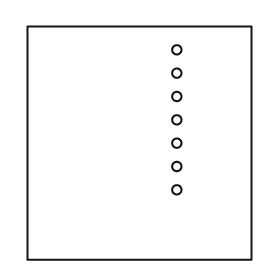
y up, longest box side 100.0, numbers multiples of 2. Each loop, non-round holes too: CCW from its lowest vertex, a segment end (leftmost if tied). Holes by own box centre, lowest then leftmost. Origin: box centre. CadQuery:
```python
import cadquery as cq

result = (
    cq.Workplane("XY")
    .moveTo(-48.0, -50.0)
    .lineTo(48.0, -50.0)
    .lineTo(48.0, 50.0)
    .lineTo(-48.0, 50.0)
    .close()
    .moveTo(16.0, -20.0)
    .circle(2.0)
    .moveTo(16.0, -10.0)
    .circle(2.0)
    .moveTo(16.0, 0.0)
    .circle(2.0)
    .moveTo(16.0, 10.0)
    .circle(2.0)
    .moveTo(16.0, 20.0)
    .circle(2.0)
    .moveTo(16.0, 30.0)
    .circle(2.0)
    .moveTo(16.0, 40.0)
    .circle(2.0)
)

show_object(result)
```